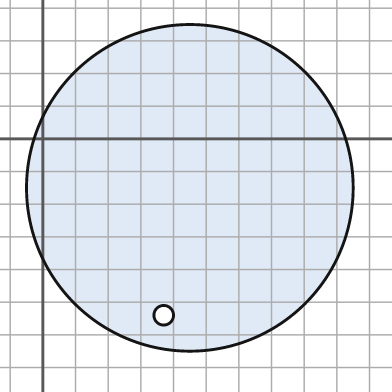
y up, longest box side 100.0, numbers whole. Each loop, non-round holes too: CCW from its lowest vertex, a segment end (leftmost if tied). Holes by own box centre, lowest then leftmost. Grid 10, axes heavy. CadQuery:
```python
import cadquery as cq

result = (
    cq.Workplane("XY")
    .moveTo(45.0, -15.0)
    .circle(50.0)
    .moveTo(37.0, -54.0)
    .circle(3.0)
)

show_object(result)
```